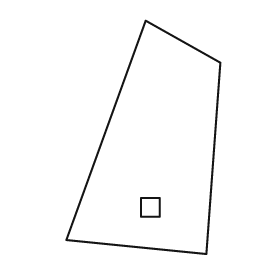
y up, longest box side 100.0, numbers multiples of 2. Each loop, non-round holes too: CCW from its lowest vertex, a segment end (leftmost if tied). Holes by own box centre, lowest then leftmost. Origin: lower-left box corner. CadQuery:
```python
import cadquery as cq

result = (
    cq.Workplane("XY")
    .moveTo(60.0, 0.0)
    .lineTo(66.0, 82.0)
    .lineTo(34.0, 100.0)
    .lineTo(0.0, 6.0)
    .close()
    .moveTo(32.0, 16.0)
    .lineTo(40.0, 16.0)
    .lineTo(40.0, 24.0)
    .lineTo(32.0, 24.0)
    .close()
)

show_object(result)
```